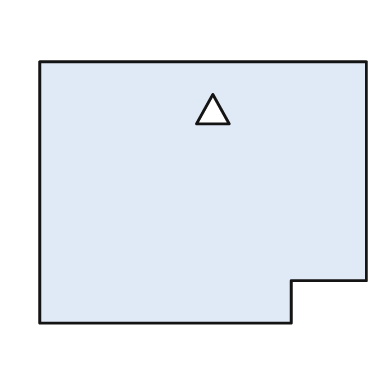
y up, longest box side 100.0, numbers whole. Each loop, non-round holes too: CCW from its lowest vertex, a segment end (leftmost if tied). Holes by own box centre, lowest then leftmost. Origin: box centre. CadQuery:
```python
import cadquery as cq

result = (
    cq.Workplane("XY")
    .moveTo(-50.0, -40.0)
    .lineTo(27.0, -40.0)
    .lineTo(27.0, -27.0)
    .lineTo(50.0, -27.0)
    .lineTo(50.0, 40.0)
    .lineTo(-50.0, 40.0)
    .close()
    .moveTo(-2.0, 21.0)
    .lineTo(8.0, 21.0)
    .lineTo(3.0, 30.0)
    .close()
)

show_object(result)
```